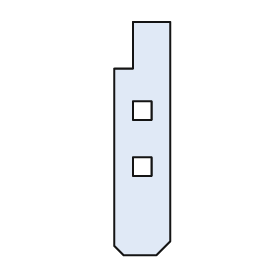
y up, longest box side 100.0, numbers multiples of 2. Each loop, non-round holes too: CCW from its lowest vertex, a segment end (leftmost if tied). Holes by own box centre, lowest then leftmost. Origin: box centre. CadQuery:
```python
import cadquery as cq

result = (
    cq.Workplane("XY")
    .moveTo(-8.0, -50.0)
    .lineTo(6.0, -50.0)
    .lineTo(12.0, -44.0)
    .lineTo(12.0, 50.0)
    .lineTo(-4.0, 50.0)
    .lineTo(-4.0, 30.0)
    .lineTo(-12.0, 30.0)
    .lineTo(-12.0, -46.0)
    .close()
    .moveTo(-4.0, -16.0)
    .lineTo(4.0, -16.0)
    .lineTo(4.0, -8.0)
    .lineTo(-4.0, -8.0)
    .close()
    .moveTo(-4.0, 8.0)
    .lineTo(4.0, 8.0)
    .lineTo(4.0, 16.0)
    .lineTo(-4.0, 16.0)
    .close()
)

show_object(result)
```